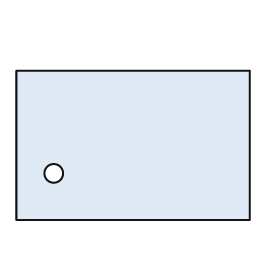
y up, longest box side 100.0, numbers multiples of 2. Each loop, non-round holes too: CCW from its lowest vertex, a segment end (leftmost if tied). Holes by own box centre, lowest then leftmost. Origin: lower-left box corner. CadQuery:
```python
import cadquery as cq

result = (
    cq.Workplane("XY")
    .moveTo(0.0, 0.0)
    .lineTo(100.0, 0.0)
    .lineTo(100.0, 64.0)
    .lineTo(0.0, 64.0)
    .close()
    .moveTo(16.0, 20.0)
    .circle(4.0)
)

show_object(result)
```